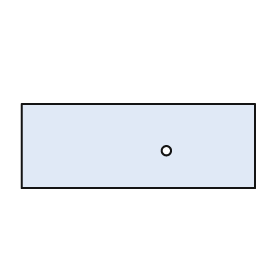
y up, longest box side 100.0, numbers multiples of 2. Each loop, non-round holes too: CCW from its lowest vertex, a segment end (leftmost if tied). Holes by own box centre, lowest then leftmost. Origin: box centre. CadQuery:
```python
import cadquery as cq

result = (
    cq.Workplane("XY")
    .moveTo(-50.0, -18.0)
    .lineTo(50.0, -18.0)
    .lineTo(50.0, 18.0)
    .lineTo(-50.0, 18.0)
    .close()
    .moveTo(12.0, -2.0)
    .circle(2.0)
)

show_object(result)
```